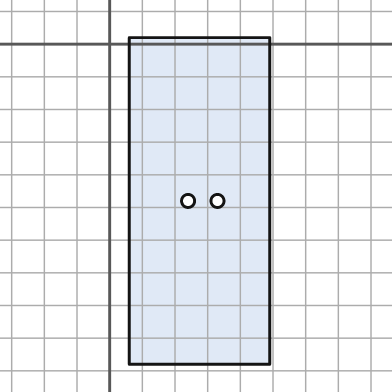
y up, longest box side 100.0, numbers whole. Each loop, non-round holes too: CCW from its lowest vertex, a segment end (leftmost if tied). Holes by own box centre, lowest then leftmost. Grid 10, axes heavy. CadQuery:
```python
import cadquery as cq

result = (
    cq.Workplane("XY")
    .moveTo(6.0, -98.0)
    .lineTo(49.0, -98.0)
    .lineTo(49.0, 2.0)
    .lineTo(6.0, 2.0)
    .close()
    .moveTo(24.0, -48.0)
    .circle(2.0)
    .moveTo(33.0, -48.0)
    .circle(2.0)
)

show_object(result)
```